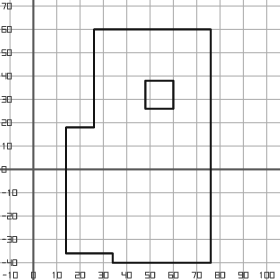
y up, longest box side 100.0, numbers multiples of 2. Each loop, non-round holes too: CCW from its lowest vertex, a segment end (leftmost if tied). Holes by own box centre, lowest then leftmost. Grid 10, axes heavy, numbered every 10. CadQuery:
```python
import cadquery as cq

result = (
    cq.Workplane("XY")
    .moveTo(34.0, -40.0)
    .lineTo(76.0, -40.0)
    .lineTo(76.0, 60.0)
    .lineTo(26.0, 60.0)
    .lineTo(26.0, 18.0)
    .lineTo(14.0, 18.0)
    .lineTo(14.0, -36.0)
    .lineTo(34.0, -36.0)
    .close()
    .moveTo(48.0, 26.0)
    .lineTo(60.0, 26.0)
    .lineTo(60.0, 38.0)
    .lineTo(48.0, 38.0)
    .close()
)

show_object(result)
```